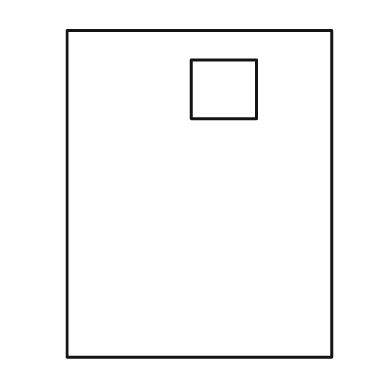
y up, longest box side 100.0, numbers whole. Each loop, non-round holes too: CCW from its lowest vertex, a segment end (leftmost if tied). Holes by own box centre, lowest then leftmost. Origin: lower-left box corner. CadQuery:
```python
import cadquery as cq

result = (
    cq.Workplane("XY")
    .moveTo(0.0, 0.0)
    .lineTo(81.0, 0.0)
    .lineTo(81.0, 100.0)
    .lineTo(0.0, 100.0)
    .close()
    .moveTo(38.0, 73.0)
    .lineTo(58.0, 73.0)
    .lineTo(58.0, 91.0)
    .lineTo(38.0, 91.0)
    .close()
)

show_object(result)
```